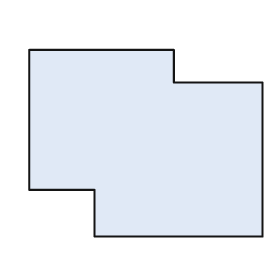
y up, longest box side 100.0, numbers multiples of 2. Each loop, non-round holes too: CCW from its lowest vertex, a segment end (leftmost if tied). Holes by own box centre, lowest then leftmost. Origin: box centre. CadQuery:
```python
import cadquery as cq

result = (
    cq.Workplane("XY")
    .moveTo(-22.0, -40.0)
    .lineTo(50.0, -40.0)
    .lineTo(50.0, 26.0)
    .lineTo(12.0, 26.0)
    .lineTo(12.0, 40.0)
    .lineTo(-50.0, 40.0)
    .lineTo(-50.0, -20.0)
    .lineTo(-22.0, -20.0)
    .close()
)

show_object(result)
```